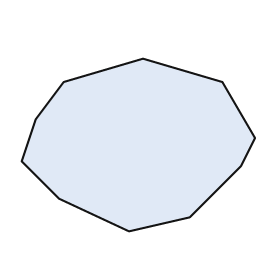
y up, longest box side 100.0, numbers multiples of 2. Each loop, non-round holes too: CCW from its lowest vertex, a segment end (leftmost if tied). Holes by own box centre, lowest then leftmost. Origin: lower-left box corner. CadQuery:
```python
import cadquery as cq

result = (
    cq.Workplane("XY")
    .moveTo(46.0, 0.0)
    .lineTo(72.0, 6.0)
    .lineTo(94.0, 28.0)
    .lineTo(100.0, 40.0)
    .lineTo(86.0, 64.0)
    .lineTo(52.0, 74.0)
    .lineTo(18.0, 64.0)
    .lineTo(6.0, 48.0)
    .lineTo(0.0, 30.0)
    .lineTo(16.0, 14.0)
    .close()
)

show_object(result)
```